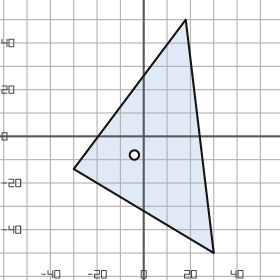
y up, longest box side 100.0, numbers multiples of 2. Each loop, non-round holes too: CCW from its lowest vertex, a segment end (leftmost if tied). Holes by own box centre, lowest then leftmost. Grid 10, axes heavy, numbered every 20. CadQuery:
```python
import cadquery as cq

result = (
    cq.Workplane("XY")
    .moveTo(30.0, -50.0)
    .lineTo(18.0, 50.0)
    .lineTo(-30.0, -14.0)
    .close()
    .moveTo(-4.0, -8.0)
    .circle(2.0)
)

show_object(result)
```